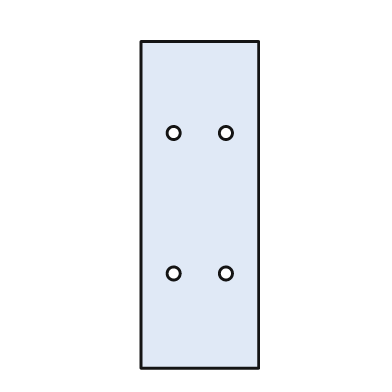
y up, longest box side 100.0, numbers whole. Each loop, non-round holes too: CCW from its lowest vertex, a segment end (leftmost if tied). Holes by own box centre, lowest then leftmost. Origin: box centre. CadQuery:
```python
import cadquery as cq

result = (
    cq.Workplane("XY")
    .moveTo(-18.0, -50.0)
    .lineTo(18.0, -50.0)
    .lineTo(18.0, 50.0)
    .lineTo(-18.0, 50.0)
    .close()
    .moveTo(-8.0, -21.0)
    .circle(2.0)
    .moveTo(8.0, -21.0)
    .circle(2.0)
    .moveTo(-8.0, 22.0)
    .circle(2.0)
    .moveTo(8.0, 22.0)
    .circle(2.0)
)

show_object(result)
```